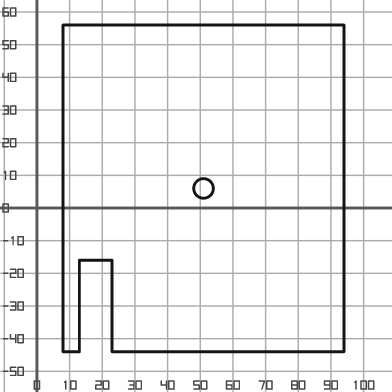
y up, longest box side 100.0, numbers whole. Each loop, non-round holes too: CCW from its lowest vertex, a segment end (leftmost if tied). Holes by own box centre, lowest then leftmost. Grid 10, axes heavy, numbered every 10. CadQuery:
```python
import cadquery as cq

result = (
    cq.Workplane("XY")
    .moveTo(8.0, -44.0)
    .lineTo(13.0, -44.0)
    .lineTo(13.0, -16.0)
    .lineTo(23.0, -16.0)
    .lineTo(23.0, -44.0)
    .lineTo(94.0, -44.0)
    .lineTo(94.0, 56.0)
    .lineTo(8.0, 56.0)
    .close()
    .moveTo(51.0, 6.0)
    .circle(3.0)
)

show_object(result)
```